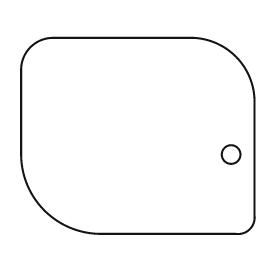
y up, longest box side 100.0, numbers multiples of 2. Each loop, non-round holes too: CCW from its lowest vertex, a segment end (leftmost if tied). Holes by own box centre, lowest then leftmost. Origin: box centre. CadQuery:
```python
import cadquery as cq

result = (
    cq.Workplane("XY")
    .moveTo(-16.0, -42.0)
    .lineTo(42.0, -42.0)
    .threePointArc((48.0, -40.0), (50.0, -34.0))
    .lineTo(50.0, 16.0)
    .threePointArc((42.0, 34.0), (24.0, 42.0))
    .lineTo(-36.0, 42.0)
    .threePointArc((-46.0, 38.0), (-50.0, 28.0))
    .lineTo(-50.0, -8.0)
    .threePointArc((-40.0, -32.0), (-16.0, -42.0))
    .close()
    .moveTo(40.0, -8.0)
    .circle(4.0)
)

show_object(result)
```